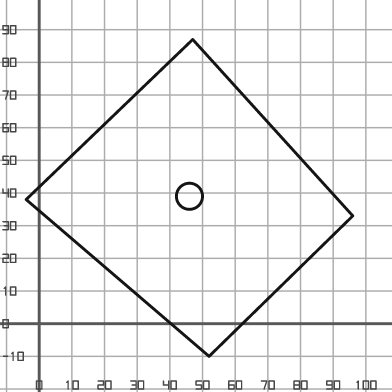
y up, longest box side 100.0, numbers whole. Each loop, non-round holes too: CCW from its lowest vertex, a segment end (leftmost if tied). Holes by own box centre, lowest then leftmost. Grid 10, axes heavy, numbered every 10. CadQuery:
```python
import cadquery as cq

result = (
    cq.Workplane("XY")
    .moveTo(52.0, -10.0)
    .lineTo(96.0, 33.0)
    .lineTo(47.0, 87.0)
    .lineTo(-4.0, 38.0)
    .close()
    .moveTo(46.0, 39.0)
    .circle(4.0)
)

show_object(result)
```